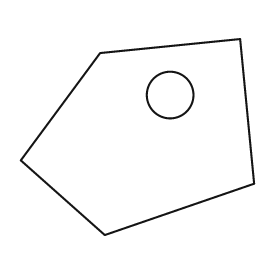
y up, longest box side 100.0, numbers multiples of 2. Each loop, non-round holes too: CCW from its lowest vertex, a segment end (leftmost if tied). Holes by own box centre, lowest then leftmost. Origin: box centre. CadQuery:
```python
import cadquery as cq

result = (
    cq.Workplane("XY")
    .moveTo(-14.0, -42.0)
    .lineTo(50.0, -20.0)
    .lineTo(44.0, 42.0)
    .lineTo(-16.0, 36.0)
    .lineTo(-50.0, -10.0)
    .close()
    .moveTo(14.0, 18.0)
    .circle(10.0)
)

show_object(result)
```